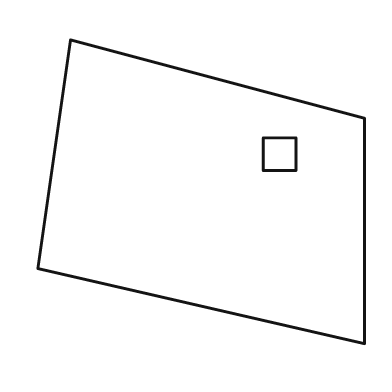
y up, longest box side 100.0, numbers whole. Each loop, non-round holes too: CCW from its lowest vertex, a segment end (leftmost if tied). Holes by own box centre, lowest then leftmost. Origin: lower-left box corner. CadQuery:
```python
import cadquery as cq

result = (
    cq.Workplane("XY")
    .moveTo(100.0, 0.0)
    .lineTo(100.0, 69.0)
    .lineTo(10.0, 93.0)
    .lineTo(0.0, 23.0)
    .close()
    .moveTo(69.0, 53.0)
    .lineTo(79.0, 53.0)
    .lineTo(79.0, 63.0)
    .lineTo(69.0, 63.0)
    .close()
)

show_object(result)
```